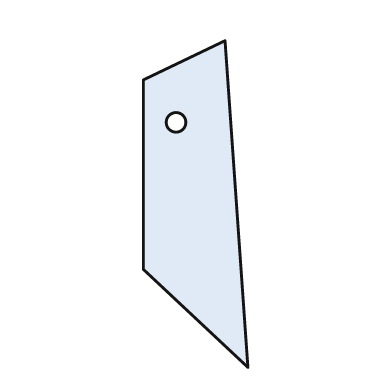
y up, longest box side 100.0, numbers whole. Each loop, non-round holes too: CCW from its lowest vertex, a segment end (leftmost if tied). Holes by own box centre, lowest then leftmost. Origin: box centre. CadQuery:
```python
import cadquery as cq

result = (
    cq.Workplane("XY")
    .moveTo(16.0, -50.0)
    .lineTo(9.0, 50.0)
    .lineTo(-16.0, 38.0)
    .lineTo(-16.0, -20.0)
    .close()
    .moveTo(-6.0, 25.0)
    .circle(3.0)
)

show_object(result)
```